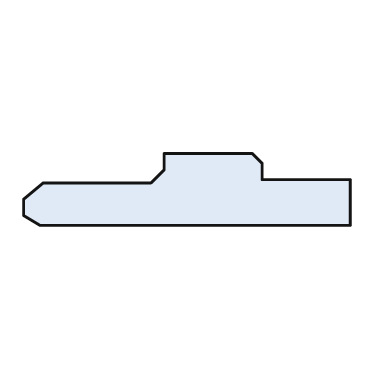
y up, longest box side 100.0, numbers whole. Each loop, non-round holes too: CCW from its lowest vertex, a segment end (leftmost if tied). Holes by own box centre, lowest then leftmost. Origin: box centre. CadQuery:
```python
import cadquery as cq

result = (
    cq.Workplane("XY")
    .moveTo(-45.0, -11.0)
    .lineTo(50.0, -11.0)
    .lineTo(50.0, 3.0)
    .lineTo(23.0, 3.0)
    .lineTo(23.0, 8.0)
    .lineTo(20.0, 11.0)
    .lineTo(-7.0, 11.0)
    .lineTo(-7.0, 6.0)
    .lineTo(-11.0, 2.0)
    .lineTo(-44.0, 2.0)
    .lineTo(-50.0, -3.0)
    .lineTo(-50.0, -8.0)
    .close()
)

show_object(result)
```